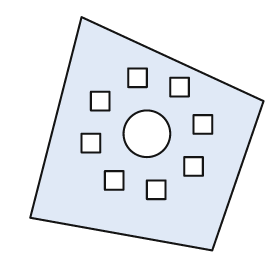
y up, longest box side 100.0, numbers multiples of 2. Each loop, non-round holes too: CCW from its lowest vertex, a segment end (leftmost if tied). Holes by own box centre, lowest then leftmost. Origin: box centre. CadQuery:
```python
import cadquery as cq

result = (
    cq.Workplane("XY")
    .moveTo(28.0, -50.0)
    .lineTo(50.0, 14.0)
    .lineTo(-28.0, 50.0)
    .lineTo(-50.0, -36.0)
    .close()
    .moveTo(0.0, -28.0)
    .lineTo(8.0, -28.0)
    .lineTo(8.0, -20.0)
    .lineTo(0.0, -20.0)
    .close()
    .moveTo(-18.0, -24.0)
    .lineTo(-10.0, -24.0)
    .lineTo(-10.0, -16.0)
    .lineTo(-18.0, -16.0)
    .close()
    .moveTo(16.0, -18.0)
    .lineTo(24.0, -18.0)
    .lineTo(24.0, -10.0)
    .lineTo(16.0, -10.0)
    .close()
    .moveTo(-28.0, -8.0)
    .lineTo(-20.0, -8.0)
    .lineTo(-20.0, 0.0)
    .lineTo(-28.0, 0.0)
    .close()
    .moveTo(0.0, 0.0)
    .circle(10.0)
    .moveTo(20.0, 0.0)
    .lineTo(28.0, 0.0)
    .lineTo(28.0, 8.0)
    .lineTo(20.0, 8.0)
    .close()
    .moveTo(-24.0, 10.0)
    .lineTo(-16.0, 10.0)
    .lineTo(-16.0, 18.0)
    .lineTo(-24.0, 18.0)
    .close()
    .moveTo(10.0, 16.0)
    .lineTo(18.0, 16.0)
    .lineTo(18.0, 24.0)
    .lineTo(10.0, 24.0)
    .close()
    .moveTo(-8.0, 20.0)
    .lineTo(0.0, 20.0)
    .lineTo(0.0, 28.0)
    .lineTo(-8.0, 28.0)
    .close()
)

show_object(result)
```